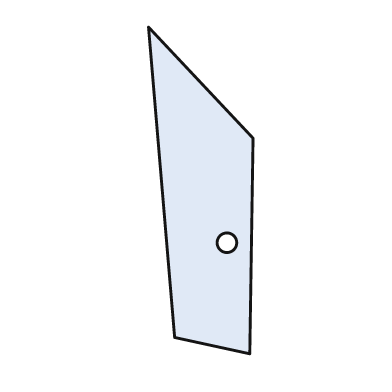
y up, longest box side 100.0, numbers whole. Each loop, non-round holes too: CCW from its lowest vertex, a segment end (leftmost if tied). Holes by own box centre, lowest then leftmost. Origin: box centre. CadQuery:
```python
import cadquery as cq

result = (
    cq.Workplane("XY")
    .moveTo(15.0, -50.0)
    .lineTo(16.0, 16.0)
    .lineTo(-16.0, 50.0)
    .lineTo(-8.0, -45.0)
    .close()
    .moveTo(8.0, -16.0)
    .circle(3.0)
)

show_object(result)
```